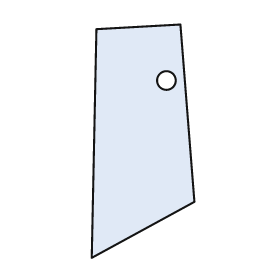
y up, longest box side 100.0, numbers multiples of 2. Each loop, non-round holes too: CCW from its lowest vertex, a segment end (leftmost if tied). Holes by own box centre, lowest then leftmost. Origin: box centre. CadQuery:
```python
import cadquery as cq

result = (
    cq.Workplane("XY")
    .moveTo(-22.0, -50.0)
    .lineTo(22.0, -26.0)
    .lineTo(16.0, 50.0)
    .lineTo(-20.0, 48.0)
    .close()
    .moveTo(10.0, 26.0)
    .circle(4.0)
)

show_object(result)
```